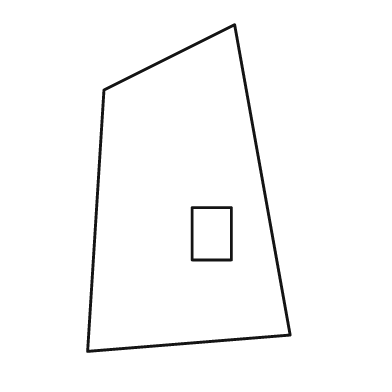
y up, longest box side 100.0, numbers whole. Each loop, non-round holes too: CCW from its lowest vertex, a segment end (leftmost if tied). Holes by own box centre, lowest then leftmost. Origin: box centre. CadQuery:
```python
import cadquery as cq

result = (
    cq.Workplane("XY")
    .moveTo(-31.0, -50.0)
    .lineTo(31.0, -45.0)
    .lineTo(14.0, 50.0)
    .lineTo(-26.0, 30.0)
    .close()
    .moveTo(1.0, -22.0)
    .lineTo(13.0, -22.0)
    .lineTo(13.0, -6.0)
    .lineTo(1.0, -6.0)
    .close()
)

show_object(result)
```